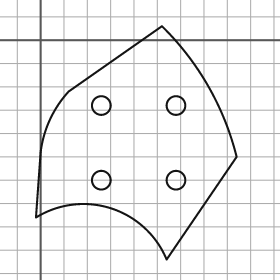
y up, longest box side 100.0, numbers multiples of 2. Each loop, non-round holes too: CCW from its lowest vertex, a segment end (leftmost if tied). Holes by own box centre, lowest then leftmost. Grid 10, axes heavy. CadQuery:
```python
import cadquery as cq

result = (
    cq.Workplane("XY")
    .moveTo(54.0, -94.0)
    .lineTo(84.0, -50.0)
    .threePointArc((72.0, -20.0), (52.0, 6.0))
    .lineTo(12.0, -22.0)
    .threePointArc((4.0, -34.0), (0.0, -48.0))
    .lineTo(-2.0, -76.0)
    .threePointArc((30.0, -72.0), (54.0, -94.0))
    .close()
    .moveTo(26.0, -60.0)
    .circle(4.0)
    .moveTo(58.0, -60.0)
    .circle(4.0)
    .moveTo(26.0, -28.0)
    .circle(4.0)
    .moveTo(58.0, -28.0)
    .circle(4.0)
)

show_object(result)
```